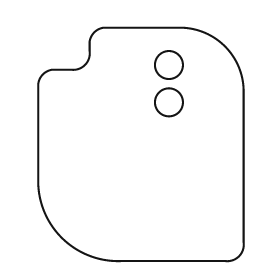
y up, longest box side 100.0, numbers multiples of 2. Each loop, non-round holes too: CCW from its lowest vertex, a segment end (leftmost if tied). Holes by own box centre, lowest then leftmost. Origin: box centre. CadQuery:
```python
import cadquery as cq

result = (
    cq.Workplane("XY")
    .moveTo(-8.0, -50.0)
    .lineTo(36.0, -50.0)
    .threePointArc((42.0, -48.0), (44.0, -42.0))
    .lineTo(44.0, 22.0)
    .threePointArc((36.0, 42.0), (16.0, 50.0))
    .lineTo(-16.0, 50.0)
    .threePointArc((-20.0, 48.0), (-22.0, 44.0))
    .lineTo(-22.0, 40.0)
    .threePointArc((-24.0, 34.0), (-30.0, 32.0))
    .lineTo(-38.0, 32.0)
    .threePointArc((-42.0, 30.0), (-44.0, 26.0))
    .lineTo(-44.0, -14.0)
    .threePointArc((-34.0, -40.0), (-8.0, -50.0))
    .close()
    .moveTo(12.0, 18.0)
    .circle(6.0)
    .moveTo(12.0, 34.0)
    .circle(6.0)
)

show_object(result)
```